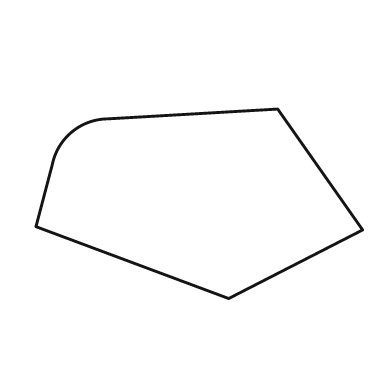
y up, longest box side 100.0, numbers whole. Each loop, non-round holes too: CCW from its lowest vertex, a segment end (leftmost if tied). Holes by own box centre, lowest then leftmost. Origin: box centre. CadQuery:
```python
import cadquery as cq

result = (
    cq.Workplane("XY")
    .moveTo(9.0, -29.0)
    .lineTo(50.0, -8.0)
    .lineTo(24.0, 29.0)
    .lineTo(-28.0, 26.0)
    .threePointArc((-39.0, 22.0), (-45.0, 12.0))
    .lineTo(-50.0, -7.0)
    .close()
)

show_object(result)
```